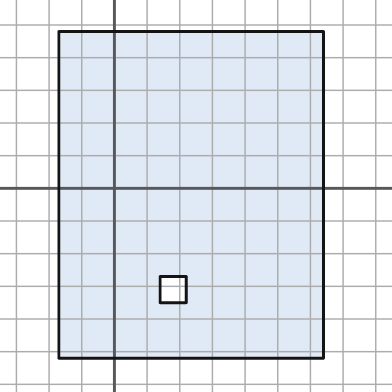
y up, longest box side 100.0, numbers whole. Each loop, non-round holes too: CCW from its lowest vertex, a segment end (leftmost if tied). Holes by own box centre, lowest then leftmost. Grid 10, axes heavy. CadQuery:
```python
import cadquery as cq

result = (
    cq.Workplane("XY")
    .moveTo(-17.0, -52.0)
    .lineTo(64.0, -52.0)
    .lineTo(64.0, 48.0)
    .lineTo(-17.0, 48.0)
    .close()
    .moveTo(14.0, -35.0)
    .lineTo(22.0, -35.0)
    .lineTo(22.0, -27.0)
    .lineTo(14.0, -27.0)
    .close()
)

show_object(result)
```